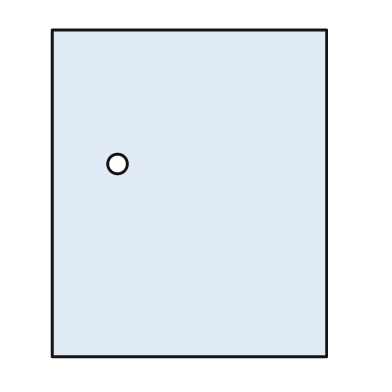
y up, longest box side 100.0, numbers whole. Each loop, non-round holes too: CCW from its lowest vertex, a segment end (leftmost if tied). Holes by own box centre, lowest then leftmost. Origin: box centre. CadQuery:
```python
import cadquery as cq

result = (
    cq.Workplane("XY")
    .moveTo(-42.0, -50.0)
    .lineTo(42.0, -50.0)
    .lineTo(42.0, 50.0)
    .lineTo(-42.0, 50.0)
    .close()
    .moveTo(-22.0, 9.0)
    .circle(3.0)
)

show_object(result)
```